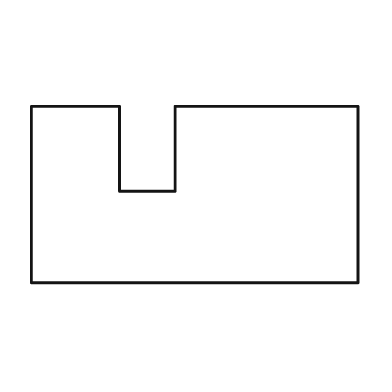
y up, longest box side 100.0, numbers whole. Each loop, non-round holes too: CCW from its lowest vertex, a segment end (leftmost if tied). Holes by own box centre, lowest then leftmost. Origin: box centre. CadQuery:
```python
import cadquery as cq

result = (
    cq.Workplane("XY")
    .moveTo(-50.0, -27.0)
    .lineTo(50.0, -27.0)
    .lineTo(50.0, 27.0)
    .lineTo(-6.0, 27.0)
    .lineTo(-6.0, 1.0)
    .lineTo(-23.0, 1.0)
    .lineTo(-23.0, 27.0)
    .lineTo(-50.0, 27.0)
    .close()
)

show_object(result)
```